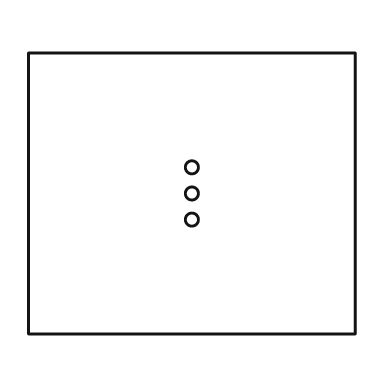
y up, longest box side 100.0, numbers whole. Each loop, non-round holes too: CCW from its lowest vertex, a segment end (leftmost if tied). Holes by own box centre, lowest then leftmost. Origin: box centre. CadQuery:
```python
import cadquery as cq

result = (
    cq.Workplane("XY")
    .moveTo(-50.0, -43.0)
    .lineTo(50.0, -43.0)
    .lineTo(50.0, 43.0)
    .lineTo(-50.0, 43.0)
    .close()
    .moveTo(0.0, -8.0)
    .circle(2.0)
    .moveTo(0.0, 0.0)
    .circle(2.0)
    .moveTo(0.0, 8.0)
    .circle(2.0)
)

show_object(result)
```